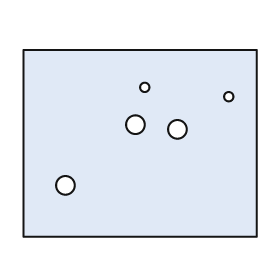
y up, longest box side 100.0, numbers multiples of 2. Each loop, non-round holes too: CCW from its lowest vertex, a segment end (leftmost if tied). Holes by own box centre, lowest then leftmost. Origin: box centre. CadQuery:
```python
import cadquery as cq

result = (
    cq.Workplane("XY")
    .moveTo(-50.0, -40.0)
    .lineTo(50.0, -40.0)
    .lineTo(50.0, 40.0)
    .lineTo(-50.0, 40.0)
    .close()
    .moveTo(-32.0, -18.0)
    .circle(4.0)
    .moveTo(16.0, 6.0)
    .circle(4.0)
    .moveTo(-2.0, 8.0)
    .circle(4.0)
    .moveTo(38.0, 20.0)
    .circle(2.0)
    .moveTo(2.0, 24.0)
    .circle(2.0)
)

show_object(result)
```